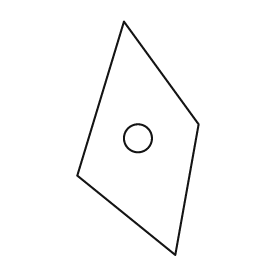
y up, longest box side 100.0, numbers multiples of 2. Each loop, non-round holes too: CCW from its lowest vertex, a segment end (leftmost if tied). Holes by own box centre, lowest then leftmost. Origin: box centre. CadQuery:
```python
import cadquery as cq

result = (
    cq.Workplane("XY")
    .moveTo(16.0, -50.0)
    .lineTo(26.0, 6.0)
    .lineTo(-6.0, 50.0)
    .lineTo(-26.0, -16.0)
    .close()
    .moveTo(0.0, 0.0)
    .circle(6.0)
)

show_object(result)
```